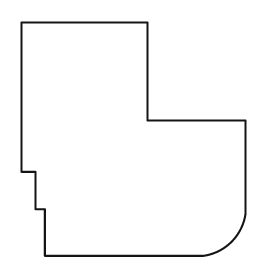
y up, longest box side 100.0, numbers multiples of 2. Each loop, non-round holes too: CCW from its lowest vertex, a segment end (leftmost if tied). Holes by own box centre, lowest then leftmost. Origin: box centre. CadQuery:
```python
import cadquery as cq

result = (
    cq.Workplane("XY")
    .moveTo(-38.0, -50.0)
    .lineTo(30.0, -50.0)
    .threePointArc((42.0, -44.0), (48.0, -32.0))
    .lineTo(48.0, 8.0)
    .lineTo(6.0, 8.0)
    .lineTo(6.0, 50.0)
    .lineTo(-48.0, 50.0)
    .lineTo(-48.0, -14.0)
    .lineTo(-42.0, -14.0)
    .lineTo(-42.0, -30.0)
    .lineTo(-38.0, -30.0)
    .close()
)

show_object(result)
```